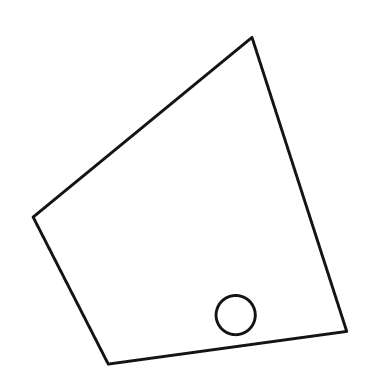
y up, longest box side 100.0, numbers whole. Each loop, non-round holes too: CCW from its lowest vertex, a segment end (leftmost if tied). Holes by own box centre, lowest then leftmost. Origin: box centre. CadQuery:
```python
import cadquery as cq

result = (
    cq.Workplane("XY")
    .moveTo(-25.0, -50.0)
    .lineTo(48.0, -40.0)
    .lineTo(19.0, 50.0)
    .lineTo(-48.0, -5.0)
    .close()
    .moveTo(14.0, -35.0)
    .circle(6.0)
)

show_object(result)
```